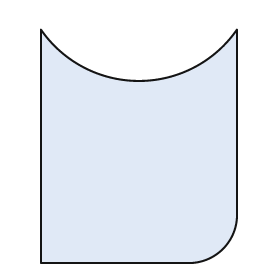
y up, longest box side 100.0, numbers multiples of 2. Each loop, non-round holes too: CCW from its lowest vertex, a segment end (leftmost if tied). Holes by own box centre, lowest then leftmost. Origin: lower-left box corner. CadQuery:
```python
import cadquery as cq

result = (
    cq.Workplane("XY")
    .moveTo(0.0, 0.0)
    .lineTo(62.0, 0.0)
    .threePointArc((78.0, 6.0), (84.0, 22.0))
    .lineTo(84.0, 100.0)
    .threePointArc((42.0, 78.0), (0.0, 100.0))
    .close()
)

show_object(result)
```